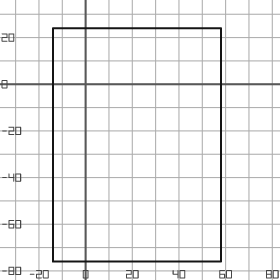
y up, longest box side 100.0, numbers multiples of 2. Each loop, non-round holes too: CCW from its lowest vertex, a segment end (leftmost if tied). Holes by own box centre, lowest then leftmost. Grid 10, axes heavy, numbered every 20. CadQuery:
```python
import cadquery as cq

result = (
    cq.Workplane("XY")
    .moveTo(-14.0, -76.0)
    .lineTo(58.0, -76.0)
    .lineTo(58.0, 24.0)
    .lineTo(-14.0, 24.0)
    .close()
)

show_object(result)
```